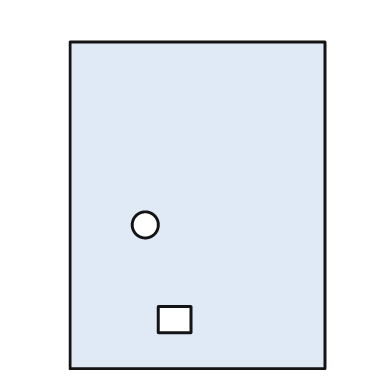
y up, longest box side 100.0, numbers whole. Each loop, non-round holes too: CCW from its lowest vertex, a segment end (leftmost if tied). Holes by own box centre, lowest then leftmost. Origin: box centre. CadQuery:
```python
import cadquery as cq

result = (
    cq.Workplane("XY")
    .moveTo(-39.0, -50.0)
    .lineTo(39.0, -50.0)
    .lineTo(39.0, 50.0)
    .lineTo(-39.0, 50.0)
    .close()
    .moveTo(-12.0, -39.0)
    .lineTo(-2.0, -39.0)
    .lineTo(-2.0, -31.0)
    .lineTo(-12.0, -31.0)
    .close()
    .moveTo(-16.0, -6.0)
    .circle(4.0)
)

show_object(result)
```